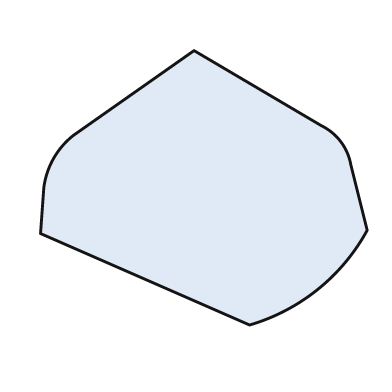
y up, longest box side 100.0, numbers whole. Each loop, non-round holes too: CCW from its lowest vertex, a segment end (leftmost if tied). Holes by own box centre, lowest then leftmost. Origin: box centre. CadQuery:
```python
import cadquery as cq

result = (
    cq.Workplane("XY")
    .moveTo(14.0, -42.0)
    .threePointArc((35.0, -31.0), (50.0, -13.0))
    .lineTo(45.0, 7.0)
    .threePointArc((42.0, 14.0), (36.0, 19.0))
    .lineTo(-3.0, 42.0)
    .lineTo(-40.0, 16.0)
    .threePointArc((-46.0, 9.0), (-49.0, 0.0))
    .lineTo(-50.0, -14.0)
    .close()
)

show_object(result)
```